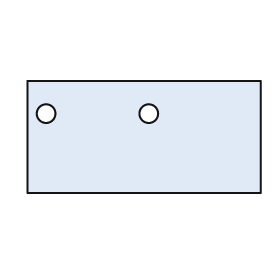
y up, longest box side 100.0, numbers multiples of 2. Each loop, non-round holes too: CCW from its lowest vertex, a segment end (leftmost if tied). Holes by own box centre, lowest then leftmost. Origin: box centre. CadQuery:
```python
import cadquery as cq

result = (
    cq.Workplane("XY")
    .moveTo(-50.0, -24.0)
    .lineTo(50.0, -24.0)
    .lineTo(50.0, 24.0)
    .lineTo(-50.0, 24.0)
    .close()
    .moveTo(-42.0, 10.0)
    .circle(4.0)
    .moveTo(2.0, 10.0)
    .circle(4.0)
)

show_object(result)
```